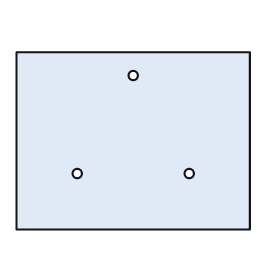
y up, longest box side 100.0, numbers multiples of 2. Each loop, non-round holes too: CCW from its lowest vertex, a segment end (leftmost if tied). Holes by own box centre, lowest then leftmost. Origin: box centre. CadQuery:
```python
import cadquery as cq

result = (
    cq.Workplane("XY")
    .moveTo(-50.0, -38.0)
    .lineTo(50.0, -38.0)
    .lineTo(50.0, 38.0)
    .lineTo(-50.0, 38.0)
    .close()
    .moveTo(-24.0, -14.0)
    .circle(2.0)
    .moveTo(24.0, -14.0)
    .circle(2.0)
    .moveTo(0.0, 28.0)
    .circle(2.0)
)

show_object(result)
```